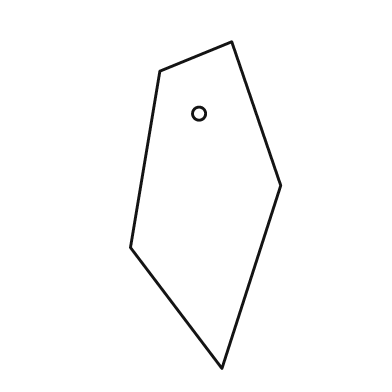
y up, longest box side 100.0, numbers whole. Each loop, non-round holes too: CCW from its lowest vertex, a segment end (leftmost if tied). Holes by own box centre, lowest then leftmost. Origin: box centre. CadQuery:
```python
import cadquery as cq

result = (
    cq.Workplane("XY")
    .moveTo(5.0, -50.0)
    .lineTo(23.0, 6.0)
    .lineTo(8.0, 50.0)
    .lineTo(-14.0, 41.0)
    .lineTo(-23.0, -13.0)
    .close()
    .moveTo(-2.0, 28.0)
    .circle(2.0)
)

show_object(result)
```